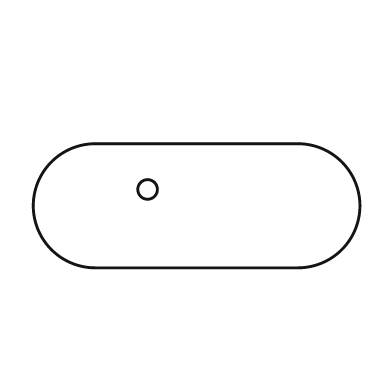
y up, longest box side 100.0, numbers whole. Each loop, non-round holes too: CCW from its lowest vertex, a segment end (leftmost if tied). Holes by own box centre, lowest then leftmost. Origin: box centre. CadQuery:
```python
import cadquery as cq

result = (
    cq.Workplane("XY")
    .moveTo(-31.0, -19.0)
    .lineTo(31.0, -19.0)
    .threePointArc((50.0, 0.0), (31.0, 19.0))
    .lineTo(-31.0, 19.0)
    .threePointArc((-50.0, 0.0), (-31.0, -19.0))
    .close()
    .moveTo(-15.0, 5.0)
    .circle(3.0)
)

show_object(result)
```